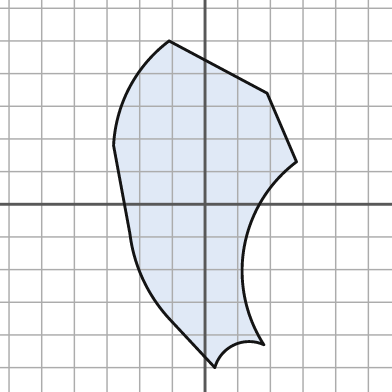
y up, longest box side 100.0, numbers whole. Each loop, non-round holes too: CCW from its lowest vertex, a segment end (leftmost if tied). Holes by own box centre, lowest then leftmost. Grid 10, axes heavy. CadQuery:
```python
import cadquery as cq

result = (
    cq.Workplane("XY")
    .moveTo(3.0, -50.0)
    .threePointArc((9.0, -43.0), (18.0, -43.0))
    .threePointArc((12.0, -13.0), (28.0, 13.0))
    .lineTo(19.0, 34.0)
    .lineTo(-11.0, 50.0)
    .threePointArc((-23.0, 36.0), (-28.0, 18.0))
    .lineTo(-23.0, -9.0)
    .threePointArc((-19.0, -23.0), (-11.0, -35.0))
    .close()
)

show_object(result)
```